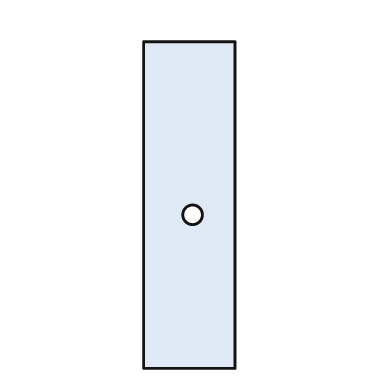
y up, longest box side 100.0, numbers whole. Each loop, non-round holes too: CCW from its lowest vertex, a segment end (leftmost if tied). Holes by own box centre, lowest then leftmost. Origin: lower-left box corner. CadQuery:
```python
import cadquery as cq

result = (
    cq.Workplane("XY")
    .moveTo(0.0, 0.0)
    .lineTo(28.0, 0.0)
    .lineTo(28.0, 100.0)
    .lineTo(0.0, 100.0)
    .close()
    .moveTo(15.0, 47.0)
    .circle(3.0)
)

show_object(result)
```